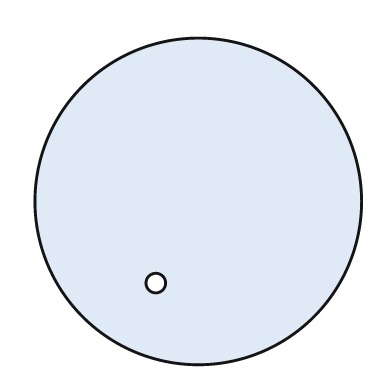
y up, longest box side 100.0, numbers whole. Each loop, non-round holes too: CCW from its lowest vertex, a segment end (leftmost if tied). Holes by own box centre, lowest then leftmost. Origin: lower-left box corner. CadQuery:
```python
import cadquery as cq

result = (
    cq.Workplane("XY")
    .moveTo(50.0, 50.0)
    .circle(50.0)
    .moveTo(37.0, 25.0)
    .circle(3.0)
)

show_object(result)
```